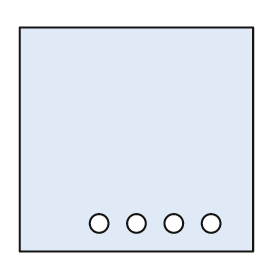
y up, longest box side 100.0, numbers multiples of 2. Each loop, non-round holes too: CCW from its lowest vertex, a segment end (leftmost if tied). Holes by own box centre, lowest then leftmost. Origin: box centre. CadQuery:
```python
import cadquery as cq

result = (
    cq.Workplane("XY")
    .moveTo(-50.0, -48.0)
    .lineTo(50.0, -48.0)
    .lineTo(50.0, 48.0)
    .lineTo(-50.0, 48.0)
    .close()
    .moveTo(-16.0, -36.0)
    .circle(4.0)
    .moveTo(0.0, -36.0)
    .circle(4.0)
    .moveTo(16.0, -36.0)
    .circle(4.0)
    .moveTo(32.0, -36.0)
    .circle(4.0)
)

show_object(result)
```